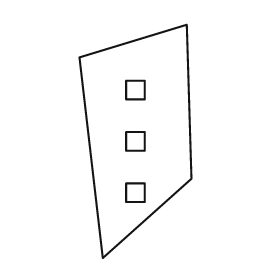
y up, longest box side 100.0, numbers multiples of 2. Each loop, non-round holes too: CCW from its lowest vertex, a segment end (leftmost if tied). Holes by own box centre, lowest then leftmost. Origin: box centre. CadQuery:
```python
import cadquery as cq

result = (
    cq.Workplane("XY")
    .moveTo(-14.0, -50.0)
    .lineTo(24.0, -16.0)
    .lineTo(22.0, 50.0)
    .lineTo(-24.0, 36.0)
    .close()
    .moveTo(-4.0, -26.0)
    .lineTo(4.0, -26.0)
    .lineTo(4.0, -18.0)
    .lineTo(-4.0, -18.0)
    .close()
    .moveTo(-4.0, -4.0)
    .lineTo(4.0, -4.0)
    .lineTo(4.0, 4.0)
    .lineTo(-4.0, 4.0)
    .close()
    .moveTo(-4.0, 18.0)
    .lineTo(4.0, 18.0)
    .lineTo(4.0, 26.0)
    .lineTo(-4.0, 26.0)
    .close()
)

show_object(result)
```